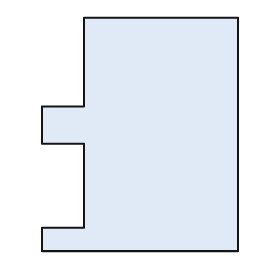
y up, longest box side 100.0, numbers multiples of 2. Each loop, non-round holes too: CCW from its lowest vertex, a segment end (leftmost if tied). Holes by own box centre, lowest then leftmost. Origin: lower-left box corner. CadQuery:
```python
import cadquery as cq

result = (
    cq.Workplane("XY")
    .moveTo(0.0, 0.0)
    .lineTo(84.0, 0.0)
    .lineTo(84.0, 100.0)
    .lineTo(18.0, 100.0)
    .lineTo(18.0, 62.0)
    .lineTo(0.0, 62.0)
    .lineTo(0.0, 46.0)
    .lineTo(18.0, 46.0)
    .lineTo(18.0, 10.0)
    .lineTo(0.0, 10.0)
    .close()
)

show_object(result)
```